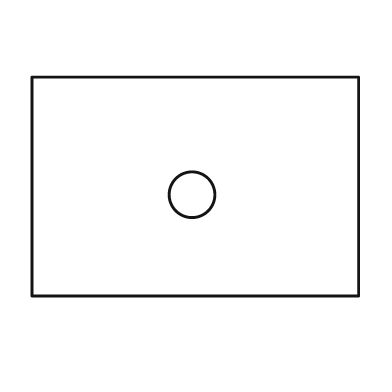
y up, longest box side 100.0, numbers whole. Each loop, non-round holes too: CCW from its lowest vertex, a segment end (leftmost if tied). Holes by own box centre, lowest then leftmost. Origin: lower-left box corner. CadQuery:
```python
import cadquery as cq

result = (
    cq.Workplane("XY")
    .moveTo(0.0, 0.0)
    .lineTo(100.0, 0.0)
    .lineTo(100.0, 67.0)
    .lineTo(0.0, 67.0)
    .close()
    .moveTo(49.0, 31.0)
    .circle(7.0)
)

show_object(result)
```